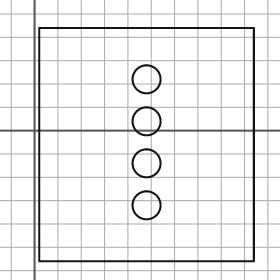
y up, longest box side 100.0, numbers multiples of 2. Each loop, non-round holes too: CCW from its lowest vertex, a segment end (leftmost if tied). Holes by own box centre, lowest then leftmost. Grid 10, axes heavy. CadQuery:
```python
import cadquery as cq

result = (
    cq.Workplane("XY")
    .moveTo(2.0, -56.0)
    .lineTo(94.0, -56.0)
    .lineTo(94.0, 44.0)
    .lineTo(2.0, 44.0)
    .close()
    .moveTo(48.0, -32.0)
    .circle(6.0)
    .moveTo(48.0, -14.0)
    .circle(6.0)
    .moveTo(48.0, 4.0)
    .circle(6.0)
    .moveTo(48.0, 22.0)
    .circle(6.0)
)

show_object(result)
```